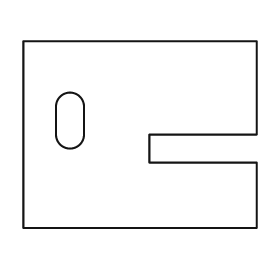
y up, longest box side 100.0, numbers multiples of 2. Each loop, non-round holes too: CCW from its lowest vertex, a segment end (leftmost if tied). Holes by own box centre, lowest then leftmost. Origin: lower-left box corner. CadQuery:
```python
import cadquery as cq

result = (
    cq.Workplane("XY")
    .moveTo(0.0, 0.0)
    .lineTo(100.0, 0.0)
    .lineTo(100.0, 28.0)
    .lineTo(54.0, 28.0)
    .lineTo(54.0, 40.0)
    .lineTo(100.0, 40.0)
    .lineTo(100.0, 80.0)
    .lineTo(0.0, 80.0)
    .close()
    .moveTo(14.0, 40.0)
    .threePointArc((20.0, 34.0), (26.0, 40.0))
    .lineTo(26.0, 52.0)
    .threePointArc((20.0, 58.0), (14.0, 52.0))
    .close()
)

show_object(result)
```